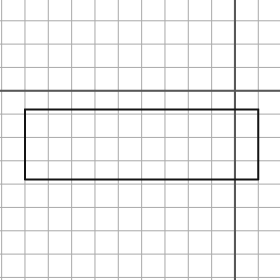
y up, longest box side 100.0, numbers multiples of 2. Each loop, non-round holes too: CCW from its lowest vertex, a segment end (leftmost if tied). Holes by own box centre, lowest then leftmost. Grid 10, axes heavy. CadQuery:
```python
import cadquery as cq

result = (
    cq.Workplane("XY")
    .moveTo(-90.0, -38.0)
    .lineTo(10.0, -38.0)
    .lineTo(10.0, -8.0)
    .lineTo(-90.0, -8.0)
    .close()
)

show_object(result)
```